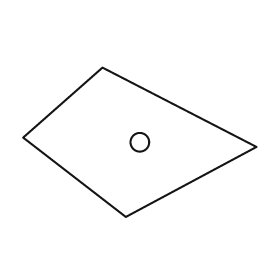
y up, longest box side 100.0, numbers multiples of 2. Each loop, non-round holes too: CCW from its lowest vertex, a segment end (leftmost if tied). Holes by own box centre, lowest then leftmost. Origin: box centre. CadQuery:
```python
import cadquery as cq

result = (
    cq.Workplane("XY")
    .moveTo(-6.0, -32.0)
    .lineTo(50.0, -2.0)
    .lineTo(-16.0, 32.0)
    .lineTo(-50.0, 2.0)
    .close()
    .moveTo(0.0, 0.0)
    .circle(4.0)
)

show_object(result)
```